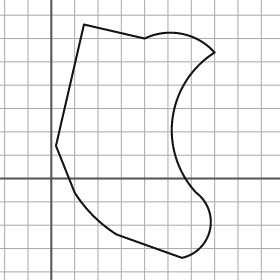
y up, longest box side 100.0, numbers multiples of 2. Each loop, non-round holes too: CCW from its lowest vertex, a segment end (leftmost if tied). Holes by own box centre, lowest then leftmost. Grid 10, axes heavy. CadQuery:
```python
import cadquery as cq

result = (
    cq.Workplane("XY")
    .moveTo(56.0, -34.0)
    .threePointArc((68.0, -22.0), (62.0, -6.0))
    .threePointArc((52.0, 26.0), (70.0, 54.0))
    .threePointArc((56.0, 62.0), (40.0, 60.0))
    .lineTo(14.0, 66.0)
    .lineTo(2.0, 14.0)
    .lineTo(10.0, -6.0)
    .threePointArc((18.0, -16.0), (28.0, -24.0))
    .close()
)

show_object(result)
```